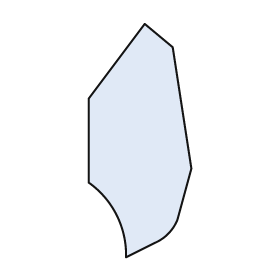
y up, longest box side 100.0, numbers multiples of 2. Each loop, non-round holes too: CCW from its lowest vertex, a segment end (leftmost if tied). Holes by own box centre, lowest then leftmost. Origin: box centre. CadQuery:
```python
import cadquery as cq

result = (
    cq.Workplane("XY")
    .moveTo(-6.0, -50.0)
    .lineTo(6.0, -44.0)
    .threePointArc((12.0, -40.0), (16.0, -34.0))
    .lineTo(22.0, -12.0)
    .lineTo(14.0, 40.0)
    .lineTo(2.0, 50.0)
    .lineTo(-22.0, 18.0)
    .lineTo(-22.0, -18.0)
    .threePointArc((-10.0, -32.0), (-6.0, -50.0))
    .close()
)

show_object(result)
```